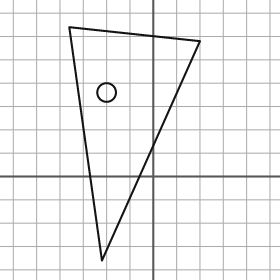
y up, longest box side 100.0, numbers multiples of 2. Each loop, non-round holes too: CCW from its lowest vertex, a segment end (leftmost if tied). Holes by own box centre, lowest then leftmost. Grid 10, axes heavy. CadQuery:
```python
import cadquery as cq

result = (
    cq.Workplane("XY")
    .moveTo(-22.0, -36.0)
    .lineTo(20.0, 58.0)
    .lineTo(-36.0, 64.0)
    .close()
    .moveTo(-20.0, 36.0)
    .circle(4.0)
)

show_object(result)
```